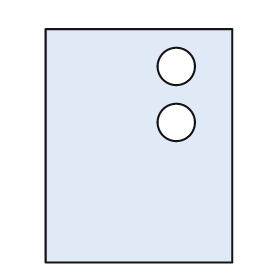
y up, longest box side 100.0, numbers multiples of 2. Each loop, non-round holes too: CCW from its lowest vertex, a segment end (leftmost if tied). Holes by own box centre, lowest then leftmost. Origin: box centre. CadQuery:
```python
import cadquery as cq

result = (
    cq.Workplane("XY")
    .moveTo(-40.0, -50.0)
    .lineTo(40.0, -50.0)
    .lineTo(40.0, 50.0)
    .lineTo(-40.0, 50.0)
    .close()
    .moveTo(16.0, 10.0)
    .circle(8.0)
    .moveTo(16.0, 34.0)
    .circle(8.0)
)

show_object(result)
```